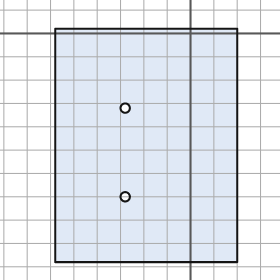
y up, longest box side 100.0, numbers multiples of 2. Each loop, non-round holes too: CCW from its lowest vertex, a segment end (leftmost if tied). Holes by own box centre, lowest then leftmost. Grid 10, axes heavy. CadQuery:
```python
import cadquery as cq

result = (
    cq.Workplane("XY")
    .moveTo(-58.0, -98.0)
    .lineTo(20.0, -98.0)
    .lineTo(20.0, 2.0)
    .lineTo(-58.0, 2.0)
    .close()
    .moveTo(-28.0, -70.0)
    .circle(2.0)
    .moveTo(-28.0, -32.0)
    .circle(2.0)
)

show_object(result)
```